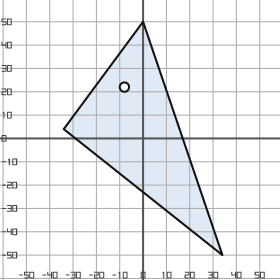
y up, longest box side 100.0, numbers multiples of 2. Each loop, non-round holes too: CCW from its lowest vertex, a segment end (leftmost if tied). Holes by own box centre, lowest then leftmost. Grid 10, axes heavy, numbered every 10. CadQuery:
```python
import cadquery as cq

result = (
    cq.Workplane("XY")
    .moveTo(34.0, -50.0)
    .lineTo(0.0, 50.0)
    .lineTo(-34.0, 4.0)
    .close()
    .moveTo(-8.0, 22.0)
    .circle(2.0)
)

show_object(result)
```